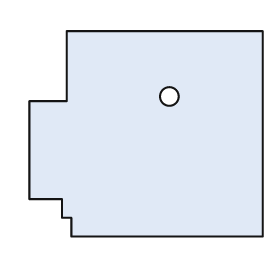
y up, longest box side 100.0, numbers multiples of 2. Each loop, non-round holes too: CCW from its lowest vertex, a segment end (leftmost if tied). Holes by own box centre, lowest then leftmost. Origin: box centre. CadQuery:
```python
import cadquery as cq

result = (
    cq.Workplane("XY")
    .moveTo(-32.0, -44.0)
    .lineTo(50.0, -44.0)
    .lineTo(50.0, 44.0)
    .lineTo(-34.0, 44.0)
    .lineTo(-34.0, 14.0)
    .lineTo(-50.0, 14.0)
    .lineTo(-50.0, -28.0)
    .lineTo(-36.0, -28.0)
    .lineTo(-36.0, -36.0)
    .lineTo(-32.0, -36.0)
    .close()
    .moveTo(10.0, 16.0)
    .circle(4.0)
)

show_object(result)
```